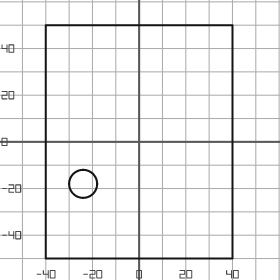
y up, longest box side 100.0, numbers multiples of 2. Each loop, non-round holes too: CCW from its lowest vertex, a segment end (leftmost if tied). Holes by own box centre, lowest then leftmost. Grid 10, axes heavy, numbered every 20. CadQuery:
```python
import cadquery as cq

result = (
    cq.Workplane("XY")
    .moveTo(-40.0, -50.0)
    .lineTo(40.0, -50.0)
    .lineTo(40.0, 50.0)
    .lineTo(-40.0, 50.0)
    .close()
    .moveTo(-24.0, -18.0)
    .circle(6.0)
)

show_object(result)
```